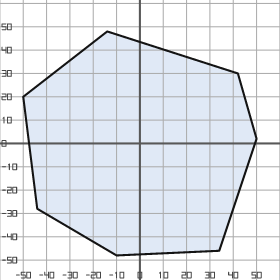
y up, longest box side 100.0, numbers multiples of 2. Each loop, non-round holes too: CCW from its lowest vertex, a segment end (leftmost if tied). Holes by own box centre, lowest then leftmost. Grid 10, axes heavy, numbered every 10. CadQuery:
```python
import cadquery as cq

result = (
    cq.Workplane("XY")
    .moveTo(-10.0, -48.0)
    .lineTo(34.0, -46.0)
    .lineTo(50.0, 2.0)
    .lineTo(42.0, 30.0)
    .lineTo(-14.0, 48.0)
    .lineTo(-50.0, 20.0)
    .lineTo(-44.0, -28.0)
    .close()
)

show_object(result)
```